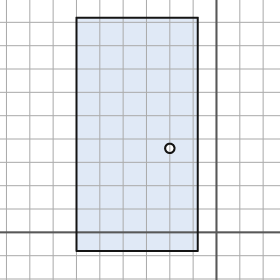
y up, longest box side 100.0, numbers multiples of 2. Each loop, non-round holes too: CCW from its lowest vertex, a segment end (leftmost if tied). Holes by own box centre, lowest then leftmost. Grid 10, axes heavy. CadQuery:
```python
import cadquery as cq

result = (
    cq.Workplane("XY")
    .moveTo(-60.0, -8.0)
    .lineTo(-8.0, -8.0)
    .lineTo(-8.0, 92.0)
    .lineTo(-60.0, 92.0)
    .close()
    .moveTo(-20.0, 36.0)
    .circle(2.0)
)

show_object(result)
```